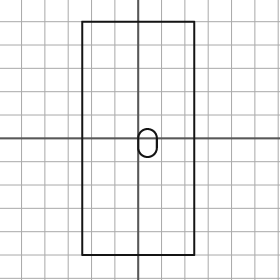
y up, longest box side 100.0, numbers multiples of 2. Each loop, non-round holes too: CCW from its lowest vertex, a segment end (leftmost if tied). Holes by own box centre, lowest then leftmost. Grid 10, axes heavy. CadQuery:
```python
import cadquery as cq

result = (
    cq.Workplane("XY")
    .moveTo(-24.0, -50.0)
    .lineTo(24.0, -50.0)
    .lineTo(24.0, 50.0)
    .lineTo(-24.0, 50.0)
    .close()
    .moveTo(0.0, -4.0)
    .threePointArc((4.0, -8.0), (8.0, -4.0))
    .lineTo(8.0, 0.0)
    .threePointArc((4.0, 4.0), (0.0, 0.0))
    .close()
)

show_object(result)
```